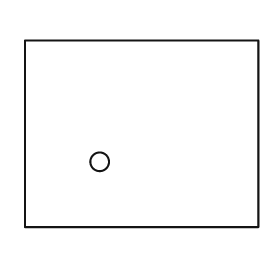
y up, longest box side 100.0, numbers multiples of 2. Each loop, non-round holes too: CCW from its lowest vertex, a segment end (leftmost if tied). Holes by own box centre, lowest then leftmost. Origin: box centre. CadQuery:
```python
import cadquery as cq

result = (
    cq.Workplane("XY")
    .moveTo(-50.0, -40.0)
    .lineTo(50.0, -40.0)
    .lineTo(50.0, 40.0)
    .lineTo(-50.0, 40.0)
    .close()
    .moveTo(-18.0, -12.0)
    .circle(4.0)
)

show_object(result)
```